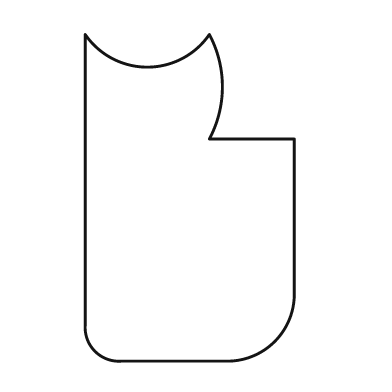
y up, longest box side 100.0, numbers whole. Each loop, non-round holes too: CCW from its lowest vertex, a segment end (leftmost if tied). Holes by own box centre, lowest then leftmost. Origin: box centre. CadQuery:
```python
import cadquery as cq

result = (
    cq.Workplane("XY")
    .moveTo(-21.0, -50.0)
    .lineTo(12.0, -50.0)
    .threePointArc((26.0, -44.0), (32.0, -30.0))
    .lineTo(32.0, 18.0)
    .lineTo(6.0, 18.0)
    .threePointArc((10.0, 34.0), (6.0, 50.0))
    .threePointArc((-13.0, 40.0), (-32.0, 50.0))
    .lineTo(-32.0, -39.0)
    .threePointArc((-29.0, -47.0), (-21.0, -50.0))
    .close()
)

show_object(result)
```